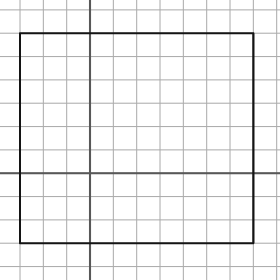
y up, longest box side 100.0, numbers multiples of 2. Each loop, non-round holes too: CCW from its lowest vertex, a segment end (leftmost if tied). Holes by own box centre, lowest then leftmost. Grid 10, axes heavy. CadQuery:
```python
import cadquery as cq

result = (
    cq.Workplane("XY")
    .moveTo(-30.0, -30.0)
    .lineTo(70.0, -30.0)
    .lineTo(70.0, 60.0)
    .lineTo(-30.0, 60.0)
    .close()
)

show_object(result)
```